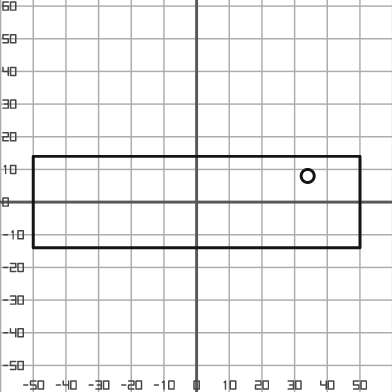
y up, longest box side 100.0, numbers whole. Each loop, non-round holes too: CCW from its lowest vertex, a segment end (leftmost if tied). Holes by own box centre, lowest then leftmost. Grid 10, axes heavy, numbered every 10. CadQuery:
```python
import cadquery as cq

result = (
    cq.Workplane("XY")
    .moveTo(-50.0, -14.0)
    .lineTo(50.0, -14.0)
    .lineTo(50.0, 14.0)
    .lineTo(-50.0, 14.0)
    .close()
    .moveTo(34.0, 8.0)
    .circle(2.0)
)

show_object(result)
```